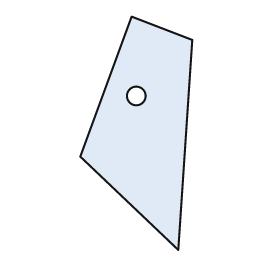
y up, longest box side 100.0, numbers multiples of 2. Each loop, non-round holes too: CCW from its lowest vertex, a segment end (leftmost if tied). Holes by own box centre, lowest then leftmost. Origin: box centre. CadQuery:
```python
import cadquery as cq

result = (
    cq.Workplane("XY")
    .moveTo(18.0, -50.0)
    .lineTo(24.0, 40.0)
    .lineTo(-2.0, 50.0)
    .lineTo(-24.0, -10.0)
    .close()
    .moveTo(0.0, 16.0)
    .circle(4.0)
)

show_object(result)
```